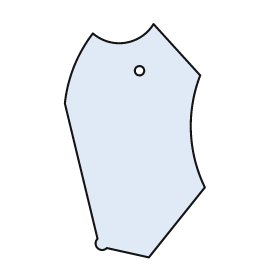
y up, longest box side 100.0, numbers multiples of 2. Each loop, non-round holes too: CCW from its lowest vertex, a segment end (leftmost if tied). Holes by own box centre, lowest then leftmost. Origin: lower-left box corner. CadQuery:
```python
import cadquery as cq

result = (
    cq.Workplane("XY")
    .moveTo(36.0, 0.0)
    .lineTo(60.0, 30.0)
    .threePointArc((54.0, 54.0), (58.0, 78.0))
    .lineTo(38.0, 100.0)
    .threePointArc((26.0, 92.0), (12.0, 96.0))
    .threePointArc((4.0, 82.0), (0.0, 66.0))
    .lineTo(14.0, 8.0)
    .threePointArc((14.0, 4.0), (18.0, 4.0))
    .close()
    .moveTo(32.0, 80.0)
    .circle(2.0)
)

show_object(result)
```